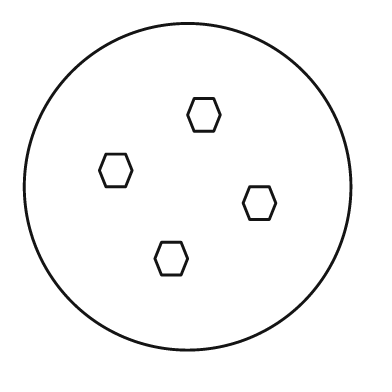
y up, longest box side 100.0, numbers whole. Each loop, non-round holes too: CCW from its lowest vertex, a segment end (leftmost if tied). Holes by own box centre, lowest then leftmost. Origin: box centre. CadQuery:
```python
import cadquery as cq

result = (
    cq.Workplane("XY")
    .moveTo(0.0, 0.0)
    .circle(50.0)
    .moveTo(-8.0, -27.0)
    .lineTo(-2.0, -27.0)
    .lineTo(0.0, -22.0)
    .lineTo(-2.0, -17.0)
    .lineTo(-8.0, -17.0)
    .lineTo(-10.0, -22.0)
    .close()
    .moveTo(19.0, -10.0)
    .lineTo(25.0, -10.0)
    .lineTo(27.0, -5.0)
    .lineTo(25.0, 0.0)
    .lineTo(19.0, 0.0)
    .lineTo(17.0, -5.0)
    .close()
    .moveTo(-25.0, 0.0)
    .lineTo(-19.0, 0.0)
    .lineTo(-17.0, 5.0)
    .lineTo(-19.0, 10.0)
    .lineTo(-25.0, 10.0)
    .lineTo(-27.0, 5.0)
    .close()
    .moveTo(2.0, 17.0)
    .lineTo(8.0, 17.0)
    .lineTo(10.0, 22.0)
    .lineTo(8.0, 27.0)
    .lineTo(2.0, 27.0)
    .lineTo(0.0, 22.0)
    .close()
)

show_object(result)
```